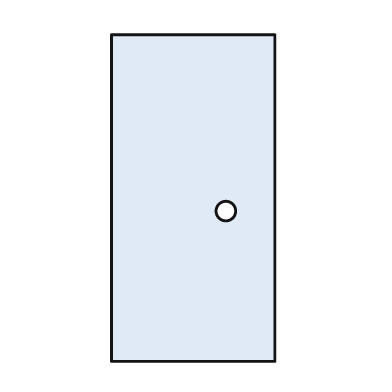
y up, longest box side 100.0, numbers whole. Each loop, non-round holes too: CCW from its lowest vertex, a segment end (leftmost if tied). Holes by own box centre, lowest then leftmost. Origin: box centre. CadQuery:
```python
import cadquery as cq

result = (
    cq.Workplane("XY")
    .moveTo(-25.0, -50.0)
    .lineTo(25.0, -50.0)
    .lineTo(25.0, 50.0)
    .lineTo(-25.0, 50.0)
    .close()
    .moveTo(10.0, -4.0)
    .circle(3.0)
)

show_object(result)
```